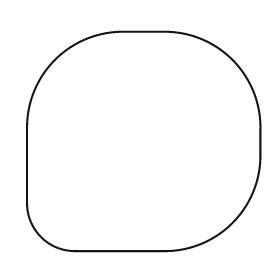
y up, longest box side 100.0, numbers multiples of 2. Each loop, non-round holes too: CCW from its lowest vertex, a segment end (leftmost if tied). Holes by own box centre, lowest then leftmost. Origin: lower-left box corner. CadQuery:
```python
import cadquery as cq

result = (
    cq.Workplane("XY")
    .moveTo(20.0, 0.0)
    .lineTo(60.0, 0.0)
    .threePointArc((88.0, 12.0), (100.0, 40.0))
    .lineTo(100.0, 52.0)
    .threePointArc((88.0, 82.0), (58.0, 94.0))
    .lineTo(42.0, 94.0)
    .threePointArc((12.0, 82.0), (0.0, 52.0))
    .lineTo(0.0, 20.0)
    .threePointArc((6.0, 6.0), (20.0, 0.0))
    .close()
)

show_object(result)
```